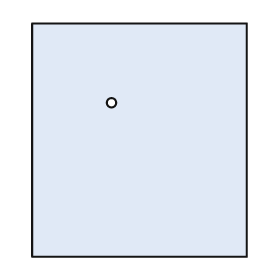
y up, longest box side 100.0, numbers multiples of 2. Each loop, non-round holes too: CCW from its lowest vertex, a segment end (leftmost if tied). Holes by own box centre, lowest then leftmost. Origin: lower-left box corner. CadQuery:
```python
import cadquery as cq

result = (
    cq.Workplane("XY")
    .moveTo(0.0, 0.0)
    .lineTo(92.0, 0.0)
    .lineTo(92.0, 100.0)
    .lineTo(0.0, 100.0)
    .close()
    .moveTo(34.0, 66.0)
    .circle(2.0)
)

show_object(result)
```